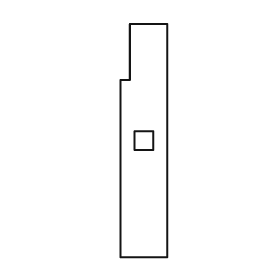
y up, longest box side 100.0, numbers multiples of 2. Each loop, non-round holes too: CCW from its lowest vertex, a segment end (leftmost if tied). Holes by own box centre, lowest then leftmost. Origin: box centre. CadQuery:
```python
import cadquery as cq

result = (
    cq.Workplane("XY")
    .moveTo(-10.0, -50.0)
    .lineTo(10.0, -50.0)
    .lineTo(10.0, 50.0)
    .lineTo(-6.0, 50.0)
    .lineTo(-6.0, 26.0)
    .lineTo(-10.0, 26.0)
    .close()
    .moveTo(-4.0, -4.0)
    .lineTo(4.0, -4.0)
    .lineTo(4.0, 4.0)
    .lineTo(-4.0, 4.0)
    .close()
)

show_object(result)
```